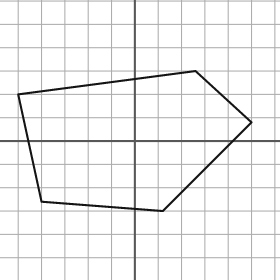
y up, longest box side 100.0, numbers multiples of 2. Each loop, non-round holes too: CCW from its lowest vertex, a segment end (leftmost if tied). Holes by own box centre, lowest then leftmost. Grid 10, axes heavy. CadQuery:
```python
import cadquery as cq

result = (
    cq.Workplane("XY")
    .moveTo(12.0, -30.0)
    .lineTo(50.0, 8.0)
    .lineTo(26.0, 30.0)
    .lineTo(-50.0, 20.0)
    .lineTo(-40.0, -26.0)
    .close()
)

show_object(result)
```